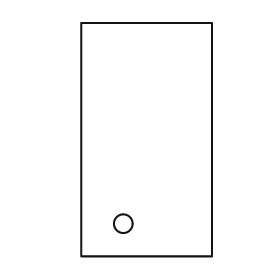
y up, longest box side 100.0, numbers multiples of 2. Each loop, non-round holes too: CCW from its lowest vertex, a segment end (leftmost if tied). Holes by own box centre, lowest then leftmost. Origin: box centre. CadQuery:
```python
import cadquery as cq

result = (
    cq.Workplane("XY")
    .moveTo(-28.0, -50.0)
    .lineTo(28.0, -50.0)
    .lineTo(28.0, 50.0)
    .lineTo(-28.0, 50.0)
    .close()
    .moveTo(-10.0, -36.0)
    .circle(4.0)
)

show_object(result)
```